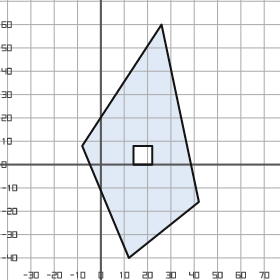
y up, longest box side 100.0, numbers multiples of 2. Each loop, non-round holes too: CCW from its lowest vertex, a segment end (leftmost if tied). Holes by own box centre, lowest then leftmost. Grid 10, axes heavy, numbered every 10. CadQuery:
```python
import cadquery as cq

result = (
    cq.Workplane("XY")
    .moveTo(12.0, -40.0)
    .lineTo(42.0, -16.0)
    .lineTo(26.0, 60.0)
    .lineTo(-8.0, 8.0)
    .close()
    .moveTo(14.0, 0.0)
    .lineTo(22.0, 0.0)
    .lineTo(22.0, 8.0)
    .lineTo(14.0, 8.0)
    .close()
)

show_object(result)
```